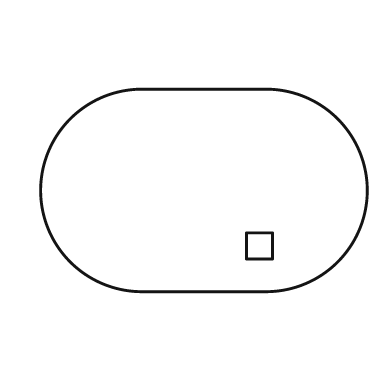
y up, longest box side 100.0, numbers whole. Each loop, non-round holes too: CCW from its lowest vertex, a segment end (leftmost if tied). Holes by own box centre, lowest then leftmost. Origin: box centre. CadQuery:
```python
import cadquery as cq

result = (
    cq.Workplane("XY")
    .moveTo(-19.0, -31.0)
    .lineTo(19.0, -31.0)
    .threePointArc((50.0, 0.0), (19.0, 31.0))
    .lineTo(-19.0, 31.0)
    .threePointArc((-50.0, 0.0), (-19.0, -31.0))
    .close()
    .moveTo(13.0, -21.0)
    .lineTo(21.0, -21.0)
    .lineTo(21.0, -13.0)
    .lineTo(13.0, -13.0)
    .close()
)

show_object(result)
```